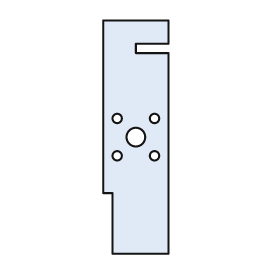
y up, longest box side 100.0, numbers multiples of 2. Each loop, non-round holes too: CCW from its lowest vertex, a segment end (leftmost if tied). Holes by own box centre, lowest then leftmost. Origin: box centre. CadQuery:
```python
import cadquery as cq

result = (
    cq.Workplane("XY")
    .moveTo(-10.0, -50.0)
    .lineTo(14.0, -50.0)
    .lineTo(14.0, 36.0)
    .lineTo(0.0, 36.0)
    .lineTo(0.0, 40.0)
    .lineTo(14.0, 40.0)
    .lineTo(14.0, 50.0)
    .lineTo(-14.0, 50.0)
    .lineTo(-14.0, -24.0)
    .lineTo(-10.0, -24.0)
    .close()
    .moveTo(-8.0, -8.0)
    .circle(2.0)
    .moveTo(8.0, -8.0)
    .circle(2.0)
    .moveTo(0.0, 0.0)
    .circle(4.0)
    .moveTo(-8.0, 8.0)
    .circle(2.0)
    .moveTo(8.0, 8.0)
    .circle(2.0)
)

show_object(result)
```